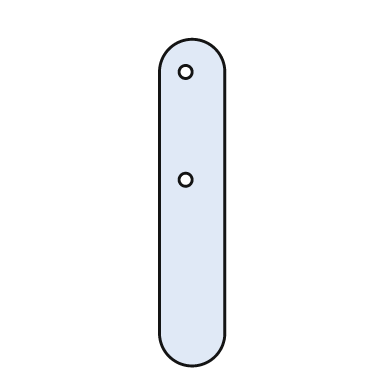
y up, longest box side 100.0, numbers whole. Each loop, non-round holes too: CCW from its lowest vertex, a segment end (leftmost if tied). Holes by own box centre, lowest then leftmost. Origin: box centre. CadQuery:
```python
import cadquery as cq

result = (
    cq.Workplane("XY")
    .moveTo(-10.0, -40.0)
    .threePointArc((0.0, -50.0), (10.0, -40.0))
    .lineTo(10.0, 40.0)
    .threePointArc((0.0, 50.0), (-10.0, 40.0))
    .close()
    .moveTo(-2.0, 7.0)
    .circle(2.0)
    .moveTo(-2.0, 40.0)
    .circle(2.0)
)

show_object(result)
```